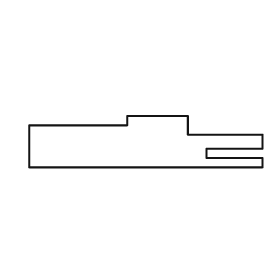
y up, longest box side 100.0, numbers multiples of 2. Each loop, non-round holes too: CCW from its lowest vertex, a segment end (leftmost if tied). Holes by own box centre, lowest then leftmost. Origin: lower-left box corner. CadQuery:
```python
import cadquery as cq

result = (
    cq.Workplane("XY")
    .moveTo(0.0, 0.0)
    .lineTo(100.0, 0.0)
    .lineTo(100.0, 4.0)
    .lineTo(76.0, 4.0)
    .lineTo(76.0, 8.0)
    .lineTo(100.0, 8.0)
    .lineTo(100.0, 14.0)
    .lineTo(68.0, 14.0)
    .lineTo(68.0, 22.0)
    .lineTo(42.0, 22.0)
    .lineTo(42.0, 18.0)
    .lineTo(0.0, 18.0)
    .close()
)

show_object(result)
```